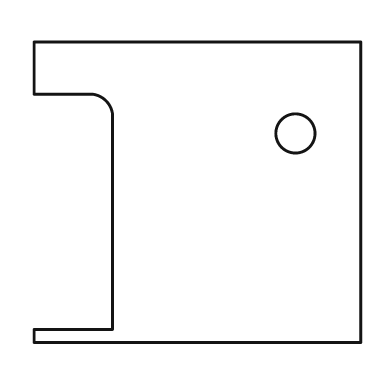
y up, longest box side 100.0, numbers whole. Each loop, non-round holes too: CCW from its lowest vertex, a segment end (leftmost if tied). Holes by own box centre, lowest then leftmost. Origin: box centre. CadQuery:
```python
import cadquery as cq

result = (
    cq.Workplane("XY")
    .moveTo(-50.0, -46.0)
    .lineTo(50.0, -46.0)
    .lineTo(50.0, 46.0)
    .lineTo(-50.0, 46.0)
    .lineTo(-50.0, 30.0)
    .lineTo(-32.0, 30.0)
    .threePointArc((-28.0, 28.0), (-26.0, 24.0))
    .lineTo(-26.0, -42.0)
    .lineTo(-50.0, -42.0)
    .close()
    .moveTo(30.0, 18.0)
    .circle(6.0)
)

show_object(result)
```